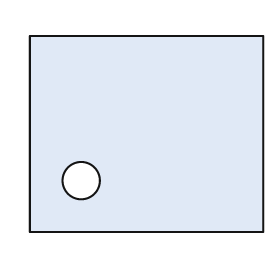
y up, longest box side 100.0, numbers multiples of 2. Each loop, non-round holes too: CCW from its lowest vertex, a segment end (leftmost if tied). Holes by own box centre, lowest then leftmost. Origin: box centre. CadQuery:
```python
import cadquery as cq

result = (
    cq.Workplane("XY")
    .moveTo(-50.0, -42.0)
    .lineTo(50.0, -42.0)
    .lineTo(50.0, 42.0)
    .lineTo(-50.0, 42.0)
    .close()
    .moveTo(-28.0, -20.0)
    .circle(8.0)
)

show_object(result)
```